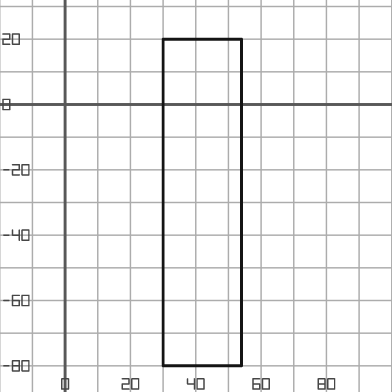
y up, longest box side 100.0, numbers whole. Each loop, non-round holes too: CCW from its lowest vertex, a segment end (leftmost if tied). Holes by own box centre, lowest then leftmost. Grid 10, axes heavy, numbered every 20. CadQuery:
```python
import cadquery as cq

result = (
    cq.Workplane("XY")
    .moveTo(30.0, -80.0)
    .lineTo(54.0, -80.0)
    .lineTo(54.0, 20.0)
    .lineTo(30.0, 20.0)
    .close()
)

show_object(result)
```